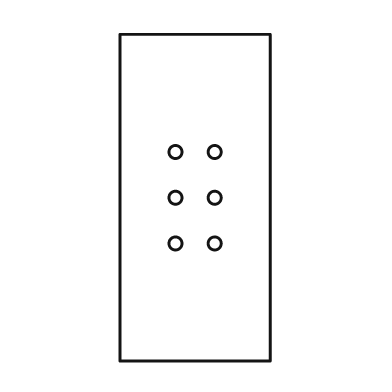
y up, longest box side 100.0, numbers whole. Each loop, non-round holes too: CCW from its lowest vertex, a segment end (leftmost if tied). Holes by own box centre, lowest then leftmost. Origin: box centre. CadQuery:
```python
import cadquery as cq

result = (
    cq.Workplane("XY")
    .moveTo(-23.0, -50.0)
    .lineTo(23.0, -50.0)
    .lineTo(23.0, 50.0)
    .lineTo(-23.0, 50.0)
    .close()
    .moveTo(-6.0, -14.0)
    .circle(2.0)
    .moveTo(6.0, -14.0)
    .circle(2.0)
    .moveTo(-6.0, 0.0)
    .circle(2.0)
    .moveTo(6.0, 0.0)
    .circle(2.0)
    .moveTo(-6.0, 14.0)
    .circle(2.0)
    .moveTo(6.0, 14.0)
    .circle(2.0)
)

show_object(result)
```